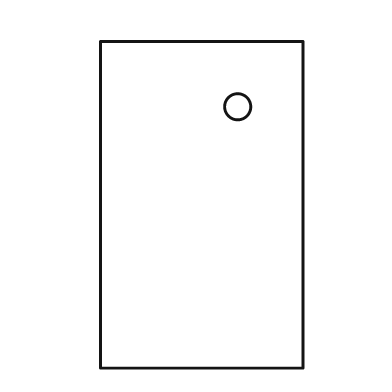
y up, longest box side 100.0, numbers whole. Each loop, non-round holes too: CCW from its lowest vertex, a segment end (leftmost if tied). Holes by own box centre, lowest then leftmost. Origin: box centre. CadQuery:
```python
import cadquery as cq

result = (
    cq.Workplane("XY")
    .moveTo(-31.0, -50.0)
    .lineTo(31.0, -50.0)
    .lineTo(31.0, 50.0)
    .lineTo(-31.0, 50.0)
    .close()
    .moveTo(11.0, 30.0)
    .circle(4.0)
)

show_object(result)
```